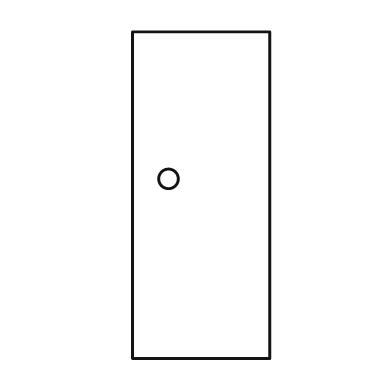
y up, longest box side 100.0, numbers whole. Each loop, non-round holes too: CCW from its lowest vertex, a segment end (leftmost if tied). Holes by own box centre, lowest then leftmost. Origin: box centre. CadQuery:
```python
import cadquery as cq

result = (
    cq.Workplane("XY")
    .moveTo(-21.0, -50.0)
    .lineTo(21.0, -50.0)
    .lineTo(21.0, 50.0)
    .lineTo(-21.0, 50.0)
    .close()
    .moveTo(-10.0, 5.0)
    .circle(3.0)
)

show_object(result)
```